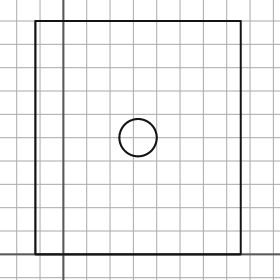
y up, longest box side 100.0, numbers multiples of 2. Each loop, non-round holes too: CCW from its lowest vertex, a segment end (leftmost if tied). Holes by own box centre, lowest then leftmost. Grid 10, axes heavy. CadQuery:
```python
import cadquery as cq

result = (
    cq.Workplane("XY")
    .moveTo(-12.0, 0.0)
    .lineTo(76.0, 0.0)
    .lineTo(76.0, 100.0)
    .lineTo(-12.0, 100.0)
    .close()
    .moveTo(32.0, 50.0)
    .circle(8.0)
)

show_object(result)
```